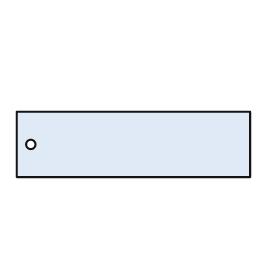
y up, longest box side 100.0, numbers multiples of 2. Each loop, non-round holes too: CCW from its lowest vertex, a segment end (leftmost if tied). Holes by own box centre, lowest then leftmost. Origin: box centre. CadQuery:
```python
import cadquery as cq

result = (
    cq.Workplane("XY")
    .moveTo(-50.0, -14.0)
    .lineTo(50.0, -14.0)
    .lineTo(50.0, 14.0)
    .lineTo(-50.0, 14.0)
    .close()
    .moveTo(-44.0, 0.0)
    .circle(2.0)
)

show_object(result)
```